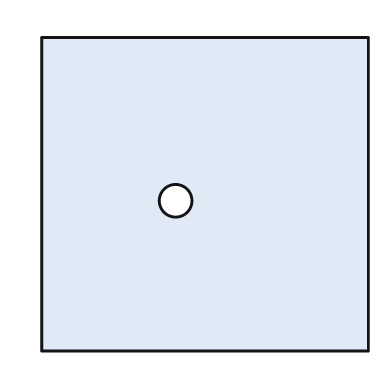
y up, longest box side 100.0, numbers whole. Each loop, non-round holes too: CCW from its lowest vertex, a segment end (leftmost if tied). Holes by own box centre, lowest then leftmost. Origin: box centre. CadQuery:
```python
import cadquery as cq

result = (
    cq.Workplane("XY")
    .moveTo(-50.0, -48.0)
    .lineTo(50.0, -48.0)
    .lineTo(50.0, 48.0)
    .lineTo(-50.0, 48.0)
    .close()
    .moveTo(-9.0, -2.0)
    .circle(5.0)
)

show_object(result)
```